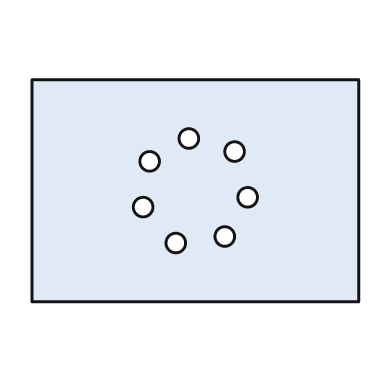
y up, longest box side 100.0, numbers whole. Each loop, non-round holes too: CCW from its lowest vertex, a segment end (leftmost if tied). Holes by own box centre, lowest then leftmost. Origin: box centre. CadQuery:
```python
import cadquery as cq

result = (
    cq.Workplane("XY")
    .moveTo(-50.0, -34.0)
    .lineTo(50.0, -34.0)
    .lineTo(50.0, 34.0)
    .lineTo(-50.0, 34.0)
    .close()
    .moveTo(-6.0, -16.0)
    .circle(3.0)
    .moveTo(9.0, -14.0)
    .circle(3.0)
    .moveTo(-16.0, -5.0)
    .circle(3.0)
    .moveTo(16.0, -2.0)
    .circle(3.0)
    .moveTo(-14.0, 9.0)
    .circle(3.0)
    .moveTo(12.0, 12.0)
    .circle(3.0)
    .moveTo(-2.0, 16.0)
    .circle(3.0)
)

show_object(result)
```